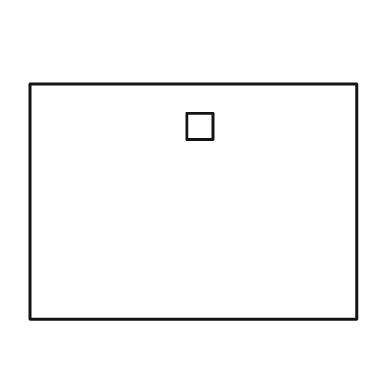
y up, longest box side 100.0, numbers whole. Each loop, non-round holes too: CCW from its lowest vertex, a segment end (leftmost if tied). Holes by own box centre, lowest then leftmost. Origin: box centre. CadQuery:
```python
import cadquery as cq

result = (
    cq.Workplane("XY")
    .moveTo(-50.0, -36.0)
    .lineTo(50.0, -36.0)
    .lineTo(50.0, 36.0)
    .lineTo(-50.0, 36.0)
    .close()
    .moveTo(-2.0, 19.0)
    .lineTo(6.0, 19.0)
    .lineTo(6.0, 27.0)
    .lineTo(-2.0, 27.0)
    .close()
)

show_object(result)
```